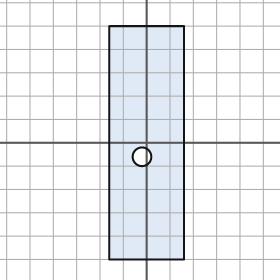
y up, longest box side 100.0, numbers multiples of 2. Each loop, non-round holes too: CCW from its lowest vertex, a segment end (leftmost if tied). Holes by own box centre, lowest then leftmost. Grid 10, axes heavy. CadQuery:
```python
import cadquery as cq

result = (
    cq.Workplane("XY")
    .moveTo(-16.0, -50.0)
    .lineTo(16.0, -50.0)
    .lineTo(16.0, 50.0)
    .lineTo(-16.0, 50.0)
    .close()
    .moveTo(-2.0, -6.0)
    .circle(4.0)
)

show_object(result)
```